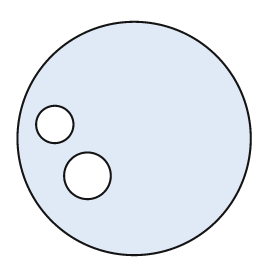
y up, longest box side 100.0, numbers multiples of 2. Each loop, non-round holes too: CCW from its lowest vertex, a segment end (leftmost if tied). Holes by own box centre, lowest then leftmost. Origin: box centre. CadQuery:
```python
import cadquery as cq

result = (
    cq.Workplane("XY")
    .moveTo(0.0, 0.0)
    .circle(50.0)
    .moveTo(-20.0, -16.0)
    .circle(10.0)
    .moveTo(-34.0, 6.0)
    .circle(8.0)
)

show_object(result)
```